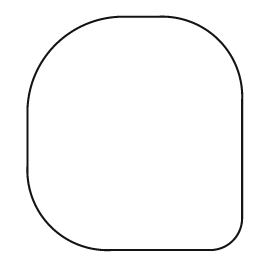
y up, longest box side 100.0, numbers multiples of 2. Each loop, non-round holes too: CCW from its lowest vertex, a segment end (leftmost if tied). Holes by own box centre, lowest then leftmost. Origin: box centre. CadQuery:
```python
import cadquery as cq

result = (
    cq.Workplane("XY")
    .moveTo(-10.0, -50.0)
    .lineTo(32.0, -50.0)
    .threePointArc((42.0, -46.0), (46.0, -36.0))
    .lineTo(46.0, 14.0)
    .threePointArc((36.0, 40.0), (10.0, 50.0))
    .lineTo(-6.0, 50.0)
    .threePointArc((-34.0, 38.0), (-46.0, 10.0))
    .lineTo(-46.0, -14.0)
    .threePointArc((-36.0, -40.0), (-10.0, -50.0))
    .close()
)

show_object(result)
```